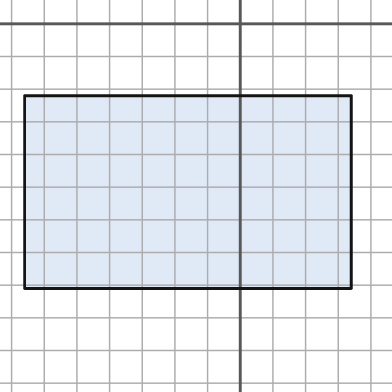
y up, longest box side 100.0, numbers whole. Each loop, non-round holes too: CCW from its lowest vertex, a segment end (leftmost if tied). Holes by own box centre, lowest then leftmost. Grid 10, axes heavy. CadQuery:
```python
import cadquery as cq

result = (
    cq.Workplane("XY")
    .moveTo(-66.0, -81.0)
    .lineTo(34.0, -81.0)
    .lineTo(34.0, -22.0)
    .lineTo(-66.0, -22.0)
    .close()
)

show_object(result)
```